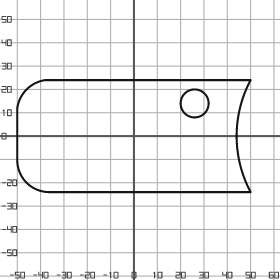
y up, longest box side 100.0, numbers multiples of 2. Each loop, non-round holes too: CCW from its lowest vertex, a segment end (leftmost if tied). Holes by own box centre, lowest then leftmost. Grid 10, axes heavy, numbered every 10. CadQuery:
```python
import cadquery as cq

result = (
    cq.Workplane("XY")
    .moveTo(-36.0, -24.0)
    .lineTo(50.0, -24.0)
    .threePointArc((44.0, 0.0), (50.0, 24.0))
    .lineTo(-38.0, 24.0)
    .threePointArc((-46.0, 20.0), (-50.0, 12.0))
    .lineTo(-50.0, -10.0)
    .threePointArc((-46.0, -20.0), (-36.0, -24.0))
    .close()
    .moveTo(26.0, 14.0)
    .circle(6.0)
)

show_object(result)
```